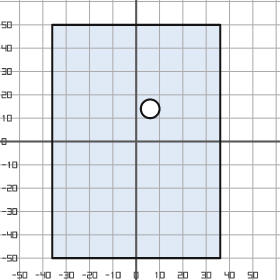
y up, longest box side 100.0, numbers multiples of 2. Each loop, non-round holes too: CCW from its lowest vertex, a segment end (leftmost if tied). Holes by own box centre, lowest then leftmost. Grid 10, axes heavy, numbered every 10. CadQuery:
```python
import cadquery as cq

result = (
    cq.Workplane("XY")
    .moveTo(-36.0, -50.0)
    .lineTo(36.0, -50.0)
    .lineTo(36.0, 50.0)
    .lineTo(-36.0, 50.0)
    .close()
    .moveTo(6.0, 14.0)
    .circle(4.0)
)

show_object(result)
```